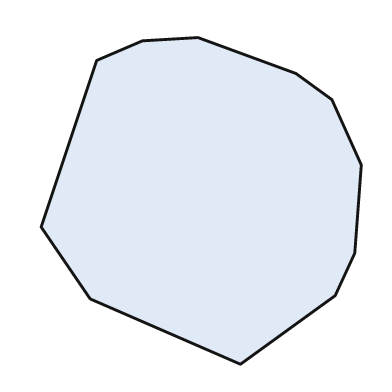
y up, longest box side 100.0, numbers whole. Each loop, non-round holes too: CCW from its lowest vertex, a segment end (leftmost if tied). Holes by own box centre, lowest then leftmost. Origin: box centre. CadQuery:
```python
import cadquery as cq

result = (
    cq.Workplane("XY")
    .moveTo(12.0, -50.0)
    .lineTo(41.0, -29.0)
    .lineTo(47.0, -16.0)
    .lineTo(49.0, 11.0)
    .lineTo(40.0, 31.0)
    .lineTo(29.0, 39.0)
    .lineTo(-1.0, 50.0)
    .lineTo(-18.0, 49.0)
    .lineTo(-32.0, 43.0)
    .lineTo(-49.0, -8.0)
    .lineTo(-34.0, -30.0)
    .close()
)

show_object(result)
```